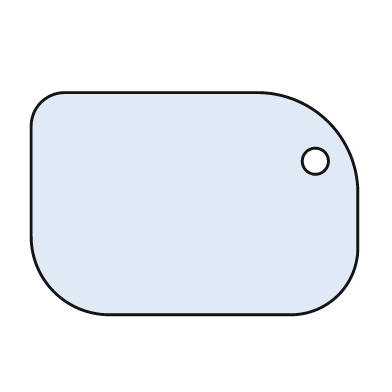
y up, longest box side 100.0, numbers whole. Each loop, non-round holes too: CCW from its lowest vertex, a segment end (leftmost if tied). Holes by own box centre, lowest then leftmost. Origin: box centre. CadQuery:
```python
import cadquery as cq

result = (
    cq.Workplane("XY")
    .moveTo(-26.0, -34.0)
    .lineTo(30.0, -34.0)
    .threePointArc((44.0, -28.0), (50.0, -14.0))
    .lineTo(50.0, 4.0)
    .threePointArc((41.0, 25.0), (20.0, 34.0))
    .lineTo(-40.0, 34.0)
    .threePointArc((-47.0, 31.0), (-50.0, 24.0))
    .lineTo(-50.0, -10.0)
    .threePointArc((-43.0, -27.0), (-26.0, -34.0))
    .close()
    .moveTo(37.0, 13.0)
    .circle(4.0)
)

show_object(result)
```